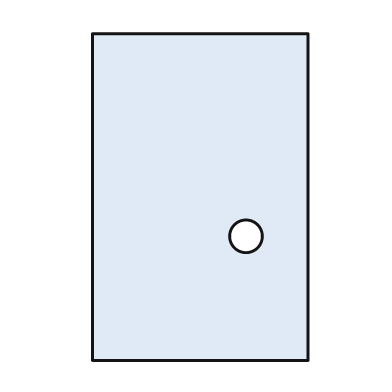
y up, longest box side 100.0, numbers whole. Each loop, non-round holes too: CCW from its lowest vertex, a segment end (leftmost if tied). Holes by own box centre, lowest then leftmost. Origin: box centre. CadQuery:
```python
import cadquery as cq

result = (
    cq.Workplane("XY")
    .moveTo(-33.0, -50.0)
    .lineTo(33.0, -50.0)
    .lineTo(33.0, 50.0)
    .lineTo(-33.0, 50.0)
    .close()
    .moveTo(14.0, -12.0)
    .circle(5.0)
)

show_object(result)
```